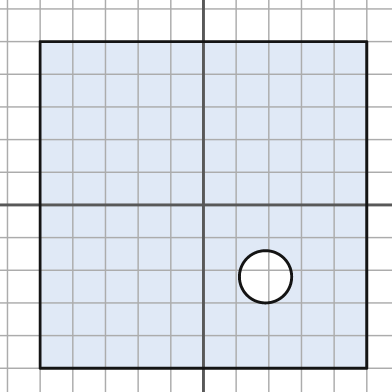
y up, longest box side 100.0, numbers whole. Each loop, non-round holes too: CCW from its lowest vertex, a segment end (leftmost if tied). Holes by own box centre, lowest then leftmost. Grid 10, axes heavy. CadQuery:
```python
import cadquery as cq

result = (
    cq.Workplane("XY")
    .moveTo(-50.0, -50.0)
    .lineTo(50.0, -50.0)
    .lineTo(50.0, 50.0)
    .lineTo(-50.0, 50.0)
    .close()
    .moveTo(19.0, -22.0)
    .circle(8.0)
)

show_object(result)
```